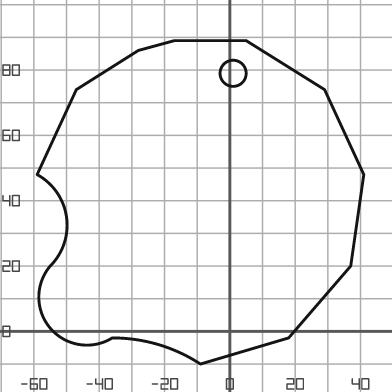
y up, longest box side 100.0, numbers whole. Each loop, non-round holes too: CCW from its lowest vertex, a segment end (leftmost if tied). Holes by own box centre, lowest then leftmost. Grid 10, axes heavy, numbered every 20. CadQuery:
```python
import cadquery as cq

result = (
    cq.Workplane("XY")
    .moveTo(-9.0, -10.0)
    .lineTo(18.0, -2.0)
    .lineTo(37.0, 20.0)
    .lineTo(41.0, 48.0)
    .lineTo(29.0, 74.0)
    .lineTo(5.0, 89.0)
    .lineTo(-17.0, 89.0)
    .lineTo(-28.0, 86.0)
    .lineTo(-47.0, 74.0)
    .lineTo(-59.0, 48.0)
    .threePointArc((-50.0, 35.0), (-55.0, 20.0))
    .threePointArc((-55.0, 1.0), (-36.0, -2.0))
    .threePointArc((-22.0, -4.0), (-9.0, -10.0))
    .close()
    .moveTo(1.0, 79.0)
    .circle(4.0)
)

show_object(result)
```